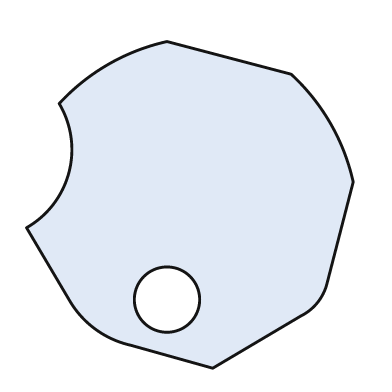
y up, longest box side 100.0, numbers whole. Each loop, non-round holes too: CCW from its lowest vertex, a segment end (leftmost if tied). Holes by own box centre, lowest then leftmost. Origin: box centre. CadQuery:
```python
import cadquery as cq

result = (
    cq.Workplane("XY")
    .moveTo(7.0, -50.0)
    .lineTo(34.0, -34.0)
    .threePointArc((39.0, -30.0), (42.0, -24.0))
    .lineTo(50.0, 7.0)
    .threePointArc((43.0, 25.0), (31.0, 40.0))
    .lineTo(-7.0, 50.0)
    .threePointArc((-25.0, 43.0), (-40.0, 31.0))
    .threePointArc((-37.0, 10.0), (-50.0, -7.0))
    .lineTo(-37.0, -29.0)
    .threePointArc((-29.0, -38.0), (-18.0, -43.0))
    .close()
    .moveTo(-7.0, -29.0)
    .circle(10.0)
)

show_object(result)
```